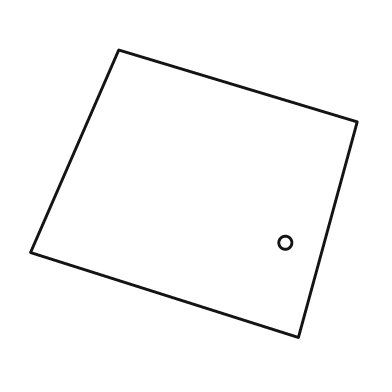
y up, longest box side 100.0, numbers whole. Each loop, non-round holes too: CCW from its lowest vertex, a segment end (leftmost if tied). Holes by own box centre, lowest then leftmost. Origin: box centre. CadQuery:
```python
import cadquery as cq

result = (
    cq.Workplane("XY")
    .moveTo(32.0, -44.0)
    .lineTo(50.0, 22.0)
    .lineTo(-23.0, 44.0)
    .lineTo(-50.0, -18.0)
    .close()
    .moveTo(28.0, -15.0)
    .circle(2.0)
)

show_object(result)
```